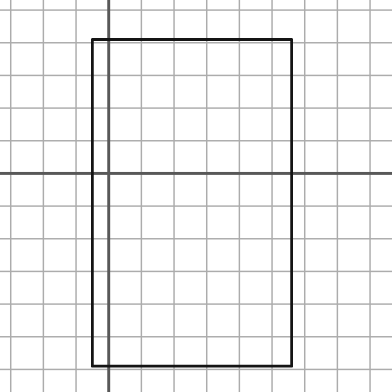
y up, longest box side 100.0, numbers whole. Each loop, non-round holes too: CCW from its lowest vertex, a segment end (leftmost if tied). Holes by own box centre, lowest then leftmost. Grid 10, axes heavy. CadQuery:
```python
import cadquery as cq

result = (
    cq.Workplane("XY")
    .moveTo(-5.0, -59.0)
    .lineTo(56.0, -59.0)
    .lineTo(56.0, 41.0)
    .lineTo(-5.0, 41.0)
    .close()
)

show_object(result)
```